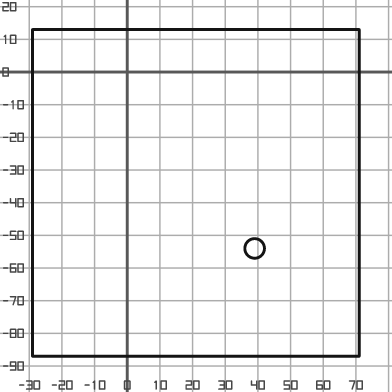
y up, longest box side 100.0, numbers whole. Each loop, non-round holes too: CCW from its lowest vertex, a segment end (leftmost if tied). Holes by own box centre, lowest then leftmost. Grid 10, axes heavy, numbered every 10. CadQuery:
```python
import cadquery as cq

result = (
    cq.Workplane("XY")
    .moveTo(-29.0, -87.0)
    .lineTo(71.0, -87.0)
    .lineTo(71.0, 13.0)
    .lineTo(-29.0, 13.0)
    .close()
    .moveTo(39.0, -54.0)
    .circle(3.0)
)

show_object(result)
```